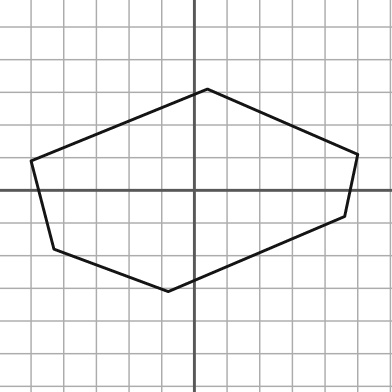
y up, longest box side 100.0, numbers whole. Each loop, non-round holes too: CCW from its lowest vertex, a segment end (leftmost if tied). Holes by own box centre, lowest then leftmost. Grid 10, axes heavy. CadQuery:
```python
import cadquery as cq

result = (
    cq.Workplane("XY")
    .moveTo(-8.0, -31.0)
    .lineTo(46.0, -8.0)
    .lineTo(50.0, 11.0)
    .lineTo(4.0, 31.0)
    .lineTo(-50.0, 9.0)
    .lineTo(-43.0, -18.0)
    .close()
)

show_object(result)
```